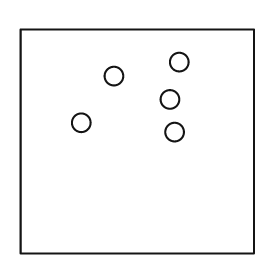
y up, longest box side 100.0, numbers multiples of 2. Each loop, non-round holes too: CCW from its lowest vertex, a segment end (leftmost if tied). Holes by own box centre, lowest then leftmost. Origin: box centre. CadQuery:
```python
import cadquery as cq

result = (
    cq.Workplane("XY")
    .moveTo(-50.0, -48.0)
    .lineTo(50.0, -48.0)
    .lineTo(50.0, 48.0)
    .lineTo(-50.0, 48.0)
    .close()
    .moveTo(16.0, 4.0)
    .circle(4.0)
    .moveTo(-24.0, 8.0)
    .circle(4.0)
    .moveTo(14.0, 18.0)
    .circle(4.0)
    .moveTo(-10.0, 28.0)
    .circle(4.0)
    .moveTo(18.0, 34.0)
    .circle(4.0)
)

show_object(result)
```